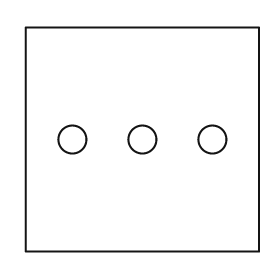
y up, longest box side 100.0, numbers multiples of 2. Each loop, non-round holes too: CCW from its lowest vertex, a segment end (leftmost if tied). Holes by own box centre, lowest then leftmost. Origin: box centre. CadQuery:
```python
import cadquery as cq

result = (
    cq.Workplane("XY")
    .moveTo(-50.0, -48.0)
    .lineTo(50.0, -48.0)
    .lineTo(50.0, 48.0)
    .lineTo(-50.0, 48.0)
    .close()
    .moveTo(-30.0, 0.0)
    .circle(6.0)
    .moveTo(0.0, 0.0)
    .circle(6.0)
    .moveTo(30.0, 0.0)
    .circle(6.0)
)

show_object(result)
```